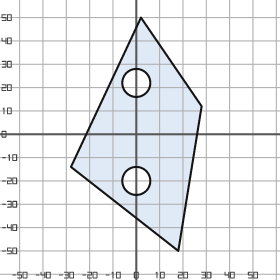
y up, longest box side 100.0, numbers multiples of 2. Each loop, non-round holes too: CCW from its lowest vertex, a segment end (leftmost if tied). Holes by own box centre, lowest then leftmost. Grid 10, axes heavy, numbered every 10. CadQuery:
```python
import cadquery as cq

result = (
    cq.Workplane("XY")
    .moveTo(18.0, -50.0)
    .lineTo(28.0, 12.0)
    .lineTo(2.0, 50.0)
    .lineTo(-28.0, -14.0)
    .close()
    .moveTo(0.0, -20.0)
    .circle(6.0)
    .moveTo(0.0, 22.0)
    .circle(6.0)
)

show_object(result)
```